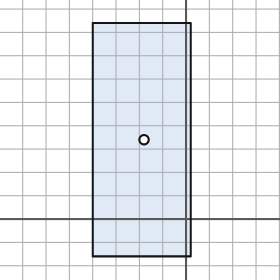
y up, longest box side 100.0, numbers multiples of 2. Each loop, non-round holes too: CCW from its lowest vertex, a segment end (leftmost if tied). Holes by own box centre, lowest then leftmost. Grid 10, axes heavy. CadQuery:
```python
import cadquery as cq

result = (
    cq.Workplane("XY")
    .moveTo(-40.0, -16.0)
    .lineTo(2.0, -16.0)
    .lineTo(2.0, 84.0)
    .lineTo(-40.0, 84.0)
    .close()
    .moveTo(-18.0, 34.0)
    .circle(2.0)
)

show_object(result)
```